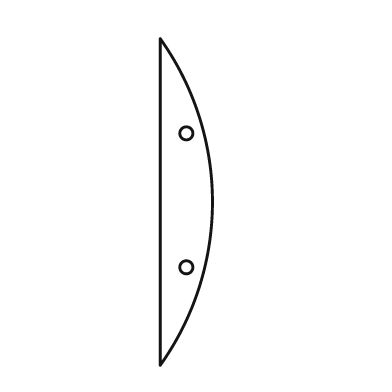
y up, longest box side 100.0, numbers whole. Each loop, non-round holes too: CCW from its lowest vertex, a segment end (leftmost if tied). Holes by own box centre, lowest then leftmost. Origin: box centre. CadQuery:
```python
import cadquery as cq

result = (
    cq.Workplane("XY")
    .moveTo(-8.0, -50.0)
    .threePointArc((8.0, 0.0), (-8.0, 50.0))
    .close()
    .moveTo(0.0, -20.0)
    .circle(2.0)
    .moveTo(0.0, 21.0)
    .circle(2.0)
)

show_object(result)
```